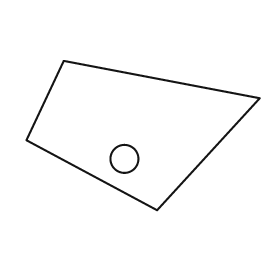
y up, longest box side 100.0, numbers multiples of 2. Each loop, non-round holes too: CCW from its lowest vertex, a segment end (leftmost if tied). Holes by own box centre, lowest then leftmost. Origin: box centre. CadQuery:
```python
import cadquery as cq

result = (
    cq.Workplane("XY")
    .moveTo(6.0, -32.0)
    .lineTo(50.0, 16.0)
    .lineTo(-34.0, 32.0)
    .lineTo(-50.0, -2.0)
    .close()
    .moveTo(-8.0, -10.0)
    .circle(6.0)
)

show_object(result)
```